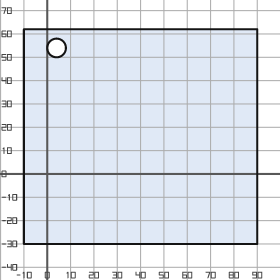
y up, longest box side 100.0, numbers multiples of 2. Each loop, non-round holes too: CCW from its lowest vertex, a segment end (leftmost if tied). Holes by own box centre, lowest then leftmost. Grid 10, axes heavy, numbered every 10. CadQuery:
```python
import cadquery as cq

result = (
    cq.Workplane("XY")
    .moveTo(-10.0, -30.0)
    .lineTo(90.0, -30.0)
    .lineTo(90.0, 62.0)
    .lineTo(-10.0, 62.0)
    .close()
    .moveTo(4.0, 54.0)
    .circle(4.0)
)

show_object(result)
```